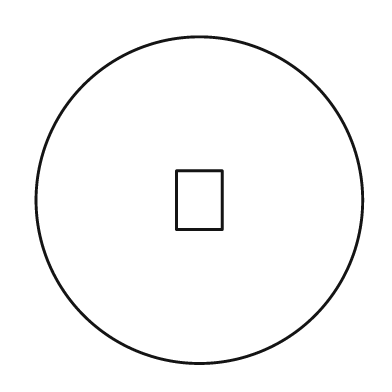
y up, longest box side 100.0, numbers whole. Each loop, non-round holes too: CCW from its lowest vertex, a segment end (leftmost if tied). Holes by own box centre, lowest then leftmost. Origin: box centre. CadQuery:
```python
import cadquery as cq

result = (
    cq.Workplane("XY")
    .moveTo(0.0, 0.0)
    .circle(50.0)
    .moveTo(-7.0, -9.0)
    .lineTo(7.0, -9.0)
    .lineTo(7.0, 9.0)
    .lineTo(-7.0, 9.0)
    .close()
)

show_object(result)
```